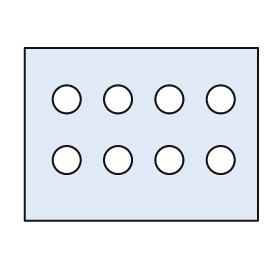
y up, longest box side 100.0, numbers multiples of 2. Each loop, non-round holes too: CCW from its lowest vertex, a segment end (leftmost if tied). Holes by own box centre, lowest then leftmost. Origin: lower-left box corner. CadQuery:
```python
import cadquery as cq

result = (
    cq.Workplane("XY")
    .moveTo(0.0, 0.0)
    .lineTo(100.0, 0.0)
    .lineTo(100.0, 74.0)
    .lineTo(0.0, 74.0)
    .close()
    .moveTo(18.0, 26.0)
    .circle(6.0)
    .moveTo(40.0, 26.0)
    .circle(6.0)
    .moveTo(62.0, 26.0)
    .circle(6.0)
    .moveTo(84.0, 26.0)
    .circle(6.0)
    .moveTo(18.0, 52.0)
    .circle(6.0)
    .moveTo(40.0, 52.0)
    .circle(6.0)
    .moveTo(62.0, 52.0)
    .circle(6.0)
    .moveTo(84.0, 52.0)
    .circle(6.0)
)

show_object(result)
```